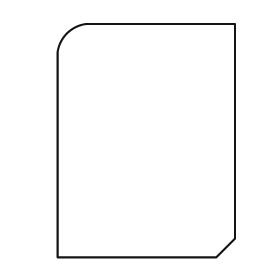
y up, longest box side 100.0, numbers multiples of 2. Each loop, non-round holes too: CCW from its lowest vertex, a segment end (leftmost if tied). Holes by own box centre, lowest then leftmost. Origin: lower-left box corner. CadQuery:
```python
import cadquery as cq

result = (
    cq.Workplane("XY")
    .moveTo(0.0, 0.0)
    .lineTo(68.0, 0.0)
    .lineTo(76.0, 8.0)
    .lineTo(76.0, 100.0)
    .lineTo(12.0, 100.0)
    .threePointArc((4.0, 96.0), (0.0, 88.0))
    .close()
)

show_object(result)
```